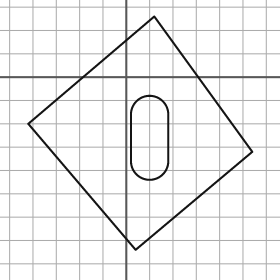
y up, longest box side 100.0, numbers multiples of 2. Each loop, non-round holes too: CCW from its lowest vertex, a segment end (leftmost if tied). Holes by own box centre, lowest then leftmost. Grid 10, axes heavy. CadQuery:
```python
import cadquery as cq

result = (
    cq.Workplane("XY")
    .moveTo(4.0, -74.0)
    .lineTo(54.0, -32.0)
    .lineTo(12.0, 26.0)
    .lineTo(-42.0, -20.0)
    .close()
    .moveTo(2.0, -36.0)
    .threePointArc((10.0, -44.0), (18.0, -36.0))
    .lineTo(18.0, -16.0)
    .threePointArc((10.0, -8.0), (2.0, -16.0))
    .close()
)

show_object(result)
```